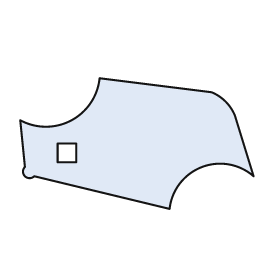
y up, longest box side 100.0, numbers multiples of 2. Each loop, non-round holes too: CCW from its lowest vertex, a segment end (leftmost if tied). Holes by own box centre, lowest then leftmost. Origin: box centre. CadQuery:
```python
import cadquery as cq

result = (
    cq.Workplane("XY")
    .moveTo(14.0, -28.0)
    .threePointArc((28.0, -10.0), (50.0, -14.0))
    .lineTo(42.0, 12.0)
    .threePointArc((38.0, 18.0), (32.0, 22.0))
    .lineTo(-16.0, 28.0)
    .threePointArc((-28.0, 10.0), (-50.0, 10.0))
    .lineTo(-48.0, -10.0)
    .threePointArc((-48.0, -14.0), (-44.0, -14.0))
    .close()
    .moveTo(-34.0, -8.0)
    .lineTo(-26.0, -8.0)
    .lineTo(-26.0, 0.0)
    .lineTo(-34.0, 0.0)
    .close()
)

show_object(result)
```